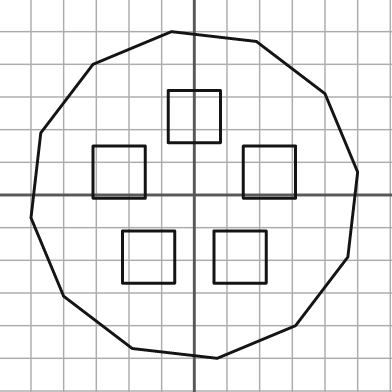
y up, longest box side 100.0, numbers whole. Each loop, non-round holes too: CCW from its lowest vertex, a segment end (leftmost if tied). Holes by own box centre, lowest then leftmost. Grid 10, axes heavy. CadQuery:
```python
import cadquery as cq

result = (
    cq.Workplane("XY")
    .moveTo(7.0, -50.0)
    .lineTo(31.0, -40.0)
    .lineTo(47.0, -19.0)
    .lineTo(50.0, 7.0)
    .lineTo(40.0, 31.0)
    .lineTo(19.0, 47.0)
    .lineTo(-7.0, 50.0)
    .lineTo(-31.0, 40.0)
    .lineTo(-47.0, 19.0)
    .lineTo(-50.0, -7.0)
    .lineTo(-40.0, -31.0)
    .lineTo(-19.0, -47.0)
    .close()
    .moveTo(-22.0, -27.0)
    .lineTo(-6.0, -27.0)
    .lineTo(-6.0, -11.0)
    .lineTo(-22.0, -11.0)
    .close()
    .moveTo(6.0, -27.0)
    .lineTo(22.0, -27.0)
    .lineTo(22.0, -11.0)
    .lineTo(6.0, -11.0)
    .close()
    .moveTo(-31.0, -1.0)
    .lineTo(-15.0, -1.0)
    .lineTo(-15.0, 15.0)
    .lineTo(-31.0, 15.0)
    .close()
    .moveTo(15.0, -1.0)
    .lineTo(31.0, -1.0)
    .lineTo(31.0, 15.0)
    .lineTo(15.0, 15.0)
    .close()
    .moveTo(-8.0, 16.0)
    .lineTo(8.0, 16.0)
    .lineTo(8.0, 32.0)
    .lineTo(-8.0, 32.0)
    .close()
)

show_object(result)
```